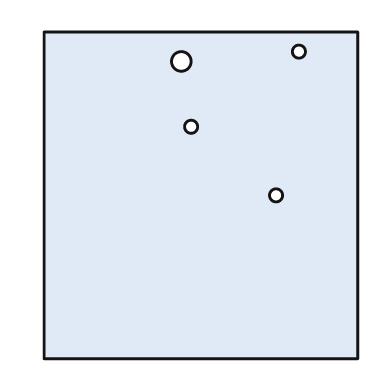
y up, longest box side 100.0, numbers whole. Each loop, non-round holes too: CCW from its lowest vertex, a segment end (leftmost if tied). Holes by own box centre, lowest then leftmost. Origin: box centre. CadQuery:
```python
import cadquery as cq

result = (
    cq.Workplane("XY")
    .moveTo(-48.0, -50.0)
    .lineTo(48.0, -50.0)
    .lineTo(48.0, 50.0)
    .lineTo(-48.0, 50.0)
    .close()
    .moveTo(23.0, 0.0)
    .circle(2.0)
    .moveTo(-3.0, 21.0)
    .circle(2.0)
    .moveTo(-6.0, 41.0)
    .circle(3.0)
    .moveTo(30.0, 44.0)
    .circle(2.0)
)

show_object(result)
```